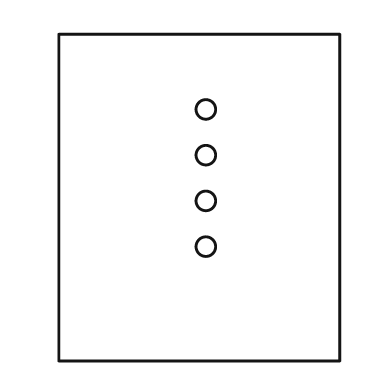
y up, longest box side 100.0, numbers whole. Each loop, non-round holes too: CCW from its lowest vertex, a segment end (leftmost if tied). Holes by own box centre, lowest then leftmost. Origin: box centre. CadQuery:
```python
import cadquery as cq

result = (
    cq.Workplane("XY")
    .moveTo(-43.0, -50.0)
    .lineTo(43.0, -50.0)
    .lineTo(43.0, 50.0)
    .lineTo(-43.0, 50.0)
    .close()
    .moveTo(2.0, -15.0)
    .circle(3.0)
    .moveTo(2.0, -1.0)
    .circle(3.0)
    .moveTo(2.0, 13.0)
    .circle(3.0)
    .moveTo(2.0, 27.0)
    .circle(3.0)
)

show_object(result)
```